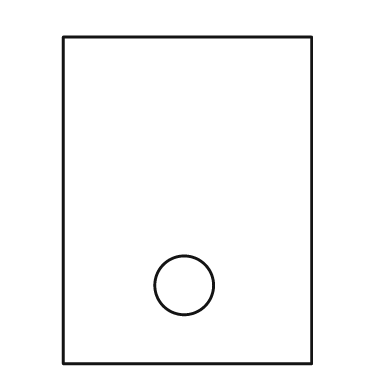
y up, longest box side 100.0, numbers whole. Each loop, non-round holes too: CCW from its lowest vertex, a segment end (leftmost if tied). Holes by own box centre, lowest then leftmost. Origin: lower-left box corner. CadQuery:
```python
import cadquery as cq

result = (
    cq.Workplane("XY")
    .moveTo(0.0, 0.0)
    .lineTo(76.0, 0.0)
    .lineTo(76.0, 100.0)
    .lineTo(0.0, 100.0)
    .close()
    .moveTo(37.0, 24.0)
    .circle(9.0)
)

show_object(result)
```